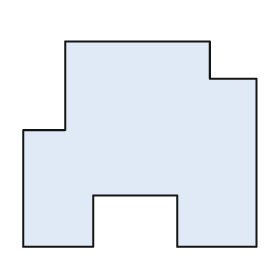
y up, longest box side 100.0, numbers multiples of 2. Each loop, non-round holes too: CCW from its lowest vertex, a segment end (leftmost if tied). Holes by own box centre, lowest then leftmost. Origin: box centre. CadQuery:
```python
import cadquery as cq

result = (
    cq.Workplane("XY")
    .moveTo(-50.0, -44.0)
    .lineTo(-20.0, -44.0)
    .lineTo(-20.0, -22.0)
    .lineTo(16.0, -22.0)
    .lineTo(16.0, -44.0)
    .lineTo(50.0, -44.0)
    .lineTo(50.0, 28.0)
    .lineTo(30.0, 28.0)
    .lineTo(30.0, 44.0)
    .lineTo(-32.0, 44.0)
    .lineTo(-32.0, 6.0)
    .lineTo(-50.0, 6.0)
    .close()
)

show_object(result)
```